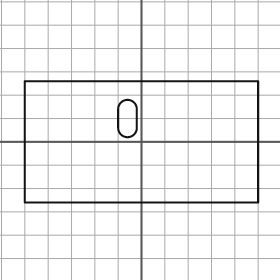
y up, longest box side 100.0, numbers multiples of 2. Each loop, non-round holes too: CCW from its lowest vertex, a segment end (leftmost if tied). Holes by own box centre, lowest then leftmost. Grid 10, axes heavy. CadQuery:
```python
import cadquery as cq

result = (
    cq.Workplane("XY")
    .moveTo(-50.0, -26.0)
    .lineTo(50.0, -26.0)
    .lineTo(50.0, 26.0)
    .lineTo(-50.0, 26.0)
    .close()
    .moveTo(-10.0, 6.0)
    .threePointArc((-6.0, 2.0), (-2.0, 6.0))
    .lineTo(-2.0, 14.0)
    .threePointArc((-6.0, 18.0), (-10.0, 14.0))
    .close()
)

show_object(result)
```